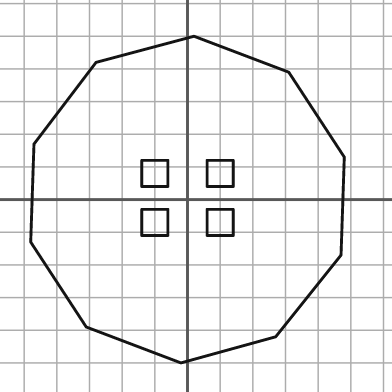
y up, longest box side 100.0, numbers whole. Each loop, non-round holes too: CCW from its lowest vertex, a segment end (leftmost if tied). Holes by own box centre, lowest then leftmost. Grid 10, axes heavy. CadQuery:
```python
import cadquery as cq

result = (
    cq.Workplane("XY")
    .moveTo(-2.0, -50.0)
    .lineTo(27.0, -42.0)
    .lineTo(47.0, -17.0)
    .lineTo(48.0, 13.0)
    .lineTo(31.0, 39.0)
    .lineTo(2.0, 50.0)
    .lineTo(-28.0, 42.0)
    .lineTo(-47.0, 17.0)
    .lineTo(-48.0, -13.0)
    .lineTo(-31.0, -39.0)
    .close()
    .moveTo(-14.0, -11.0)
    .lineTo(-6.0, -11.0)
    .lineTo(-6.0, -3.0)
    .lineTo(-14.0, -3.0)
    .close()
    .moveTo(6.0, -11.0)
    .lineTo(14.0, -11.0)
    .lineTo(14.0, -3.0)
    .lineTo(6.0, -3.0)
    .close()
    .moveTo(-14.0, 4.0)
    .lineTo(-6.0, 4.0)
    .lineTo(-6.0, 12.0)
    .lineTo(-14.0, 12.0)
    .close()
    .moveTo(6.0, 4.0)
    .lineTo(14.0, 4.0)
    .lineTo(14.0, 12.0)
    .lineTo(6.0, 12.0)
    .close()
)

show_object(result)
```